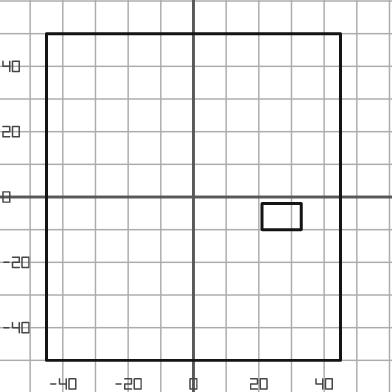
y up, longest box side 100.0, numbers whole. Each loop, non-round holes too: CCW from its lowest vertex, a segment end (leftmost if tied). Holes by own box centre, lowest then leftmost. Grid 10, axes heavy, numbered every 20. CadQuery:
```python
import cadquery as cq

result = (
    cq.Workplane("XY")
    .moveTo(-45.0, -50.0)
    .lineTo(45.0, -50.0)
    .lineTo(45.0, 50.0)
    .lineTo(-45.0, 50.0)
    .close()
    .moveTo(21.0, -10.0)
    .lineTo(33.0, -10.0)
    .lineTo(33.0, -2.0)
    .lineTo(21.0, -2.0)
    .close()
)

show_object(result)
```